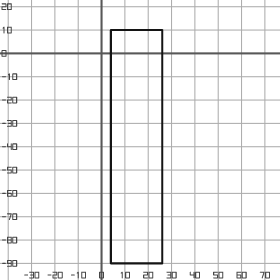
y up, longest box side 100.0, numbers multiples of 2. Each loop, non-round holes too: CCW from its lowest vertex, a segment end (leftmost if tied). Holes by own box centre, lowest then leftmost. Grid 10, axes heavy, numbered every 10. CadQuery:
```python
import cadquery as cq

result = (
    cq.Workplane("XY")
    .moveTo(4.0, -90.0)
    .lineTo(26.0, -90.0)
    .lineTo(26.0, 10.0)
    .lineTo(4.0, 10.0)
    .close()
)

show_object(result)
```